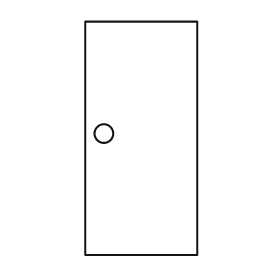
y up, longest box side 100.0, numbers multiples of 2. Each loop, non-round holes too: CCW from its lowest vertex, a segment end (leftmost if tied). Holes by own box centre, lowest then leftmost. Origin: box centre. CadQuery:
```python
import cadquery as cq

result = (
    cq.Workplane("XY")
    .moveTo(-24.0, -50.0)
    .lineTo(24.0, -50.0)
    .lineTo(24.0, 50.0)
    .lineTo(-24.0, 50.0)
    .close()
    .moveTo(-16.0, 2.0)
    .circle(4.0)
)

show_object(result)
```